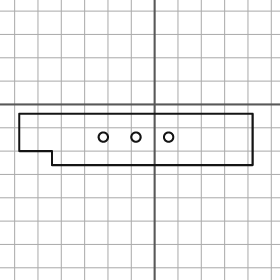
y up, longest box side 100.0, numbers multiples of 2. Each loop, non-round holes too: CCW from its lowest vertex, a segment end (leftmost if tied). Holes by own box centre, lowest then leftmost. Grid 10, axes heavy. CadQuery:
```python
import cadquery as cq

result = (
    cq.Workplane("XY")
    .moveTo(-44.0, -26.0)
    .lineTo(42.0, -26.0)
    .lineTo(42.0, -4.0)
    .lineTo(-58.0, -4.0)
    .lineTo(-58.0, -20.0)
    .lineTo(-44.0, -20.0)
    .close()
    .moveTo(-22.0, -14.0)
    .circle(2.0)
    .moveTo(-8.0, -14.0)
    .circle(2.0)
    .moveTo(6.0, -14.0)
    .circle(2.0)
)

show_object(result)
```